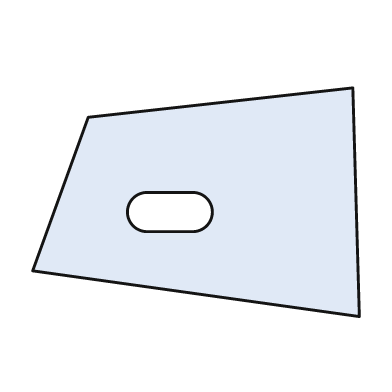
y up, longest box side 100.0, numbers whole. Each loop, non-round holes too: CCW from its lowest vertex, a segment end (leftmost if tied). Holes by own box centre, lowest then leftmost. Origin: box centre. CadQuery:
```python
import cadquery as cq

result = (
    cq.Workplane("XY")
    .moveTo(50.0, -35.0)
    .lineTo(48.0, 35.0)
    .lineTo(-33.0, 26.0)
    .lineTo(-50.0, -21.0)
    .close()
    .moveTo(-15.0, -9.0)
    .lineTo(-1.0, -9.0)
    .threePointArc((5.0, -3.0), (-1.0, 3.0))
    .lineTo(-15.0, 3.0)
    .threePointArc((-21.0, -3.0), (-15.0, -9.0))
    .close()
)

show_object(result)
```